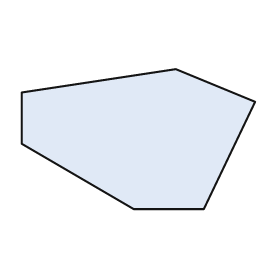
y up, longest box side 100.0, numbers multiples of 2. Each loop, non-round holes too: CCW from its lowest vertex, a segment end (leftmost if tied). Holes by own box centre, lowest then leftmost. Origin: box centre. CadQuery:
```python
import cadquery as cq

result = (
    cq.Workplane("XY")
    .moveTo(-2.0, -30.0)
    .lineTo(28.0, -30.0)
    .lineTo(50.0, 16.0)
    .lineTo(16.0, 30.0)
    .lineTo(-50.0, 20.0)
    .lineTo(-50.0, -2.0)
    .close()
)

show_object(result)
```